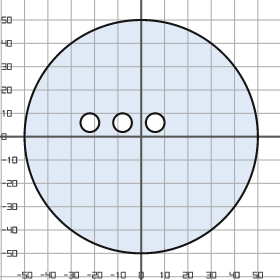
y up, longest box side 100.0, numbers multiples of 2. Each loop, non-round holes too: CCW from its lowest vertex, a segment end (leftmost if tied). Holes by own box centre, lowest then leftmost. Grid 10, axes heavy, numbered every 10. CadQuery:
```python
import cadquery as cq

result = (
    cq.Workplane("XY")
    .moveTo(0.0, 0.0)
    .circle(50.0)
    .moveTo(-22.0, 6.0)
    .circle(4.0)
    .moveTo(-8.0, 6.0)
    .circle(4.0)
    .moveTo(6.0, 6.0)
    .circle(4.0)
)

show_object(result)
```